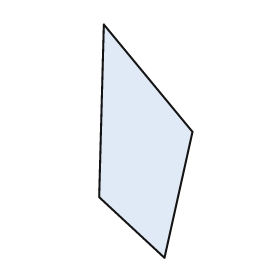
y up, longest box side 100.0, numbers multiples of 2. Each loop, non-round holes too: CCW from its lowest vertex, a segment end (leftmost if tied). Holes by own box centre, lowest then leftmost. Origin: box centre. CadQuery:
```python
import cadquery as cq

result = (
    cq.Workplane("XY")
    .moveTo(8.0, -50.0)
    .lineTo(20.0, 4.0)
    .lineTo(-18.0, 50.0)
    .lineTo(-20.0, -24.0)
    .close()
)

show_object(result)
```